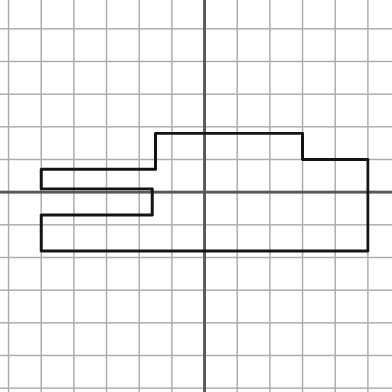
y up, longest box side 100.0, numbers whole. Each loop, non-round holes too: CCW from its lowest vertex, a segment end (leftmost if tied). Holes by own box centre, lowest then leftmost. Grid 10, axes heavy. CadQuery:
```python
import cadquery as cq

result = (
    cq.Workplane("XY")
    .moveTo(-50.0, -18.0)
    .lineTo(50.0, -18.0)
    .lineTo(50.0, 10.0)
    .lineTo(30.0, 10.0)
    .lineTo(30.0, 18.0)
    .lineTo(-15.0, 18.0)
    .lineTo(-15.0, 7.0)
    .lineTo(-50.0, 7.0)
    .lineTo(-50.0, 1.0)
    .lineTo(-16.0, 1.0)
    .lineTo(-16.0, -7.0)
    .lineTo(-50.0, -7.0)
    .close()
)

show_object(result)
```